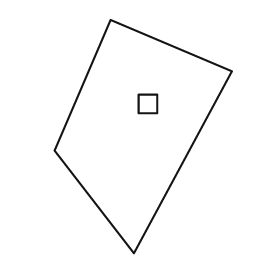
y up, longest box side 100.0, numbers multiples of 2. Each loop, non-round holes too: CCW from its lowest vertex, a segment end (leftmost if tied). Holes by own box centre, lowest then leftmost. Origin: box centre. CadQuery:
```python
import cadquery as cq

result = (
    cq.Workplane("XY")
    .moveTo(-4.0, -50.0)
    .lineTo(38.0, 28.0)
    .lineTo(-14.0, 50.0)
    .lineTo(-38.0, -6.0)
    .close()
    .moveTo(-2.0, 10.0)
    .lineTo(6.0, 10.0)
    .lineTo(6.0, 18.0)
    .lineTo(-2.0, 18.0)
    .close()
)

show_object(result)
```